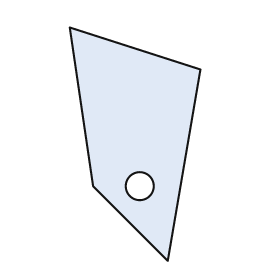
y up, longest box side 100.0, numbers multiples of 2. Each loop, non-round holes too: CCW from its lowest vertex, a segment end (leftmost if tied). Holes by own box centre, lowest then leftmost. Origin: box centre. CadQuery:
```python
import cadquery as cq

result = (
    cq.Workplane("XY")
    .moveTo(14.0, -50.0)
    .lineTo(28.0, 32.0)
    .lineTo(-28.0, 50.0)
    .lineTo(-18.0, -18.0)
    .close()
    .moveTo(2.0, -18.0)
    .circle(6.0)
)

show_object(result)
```